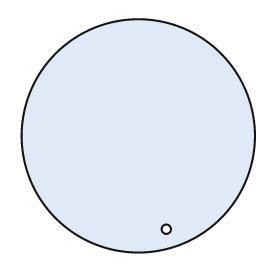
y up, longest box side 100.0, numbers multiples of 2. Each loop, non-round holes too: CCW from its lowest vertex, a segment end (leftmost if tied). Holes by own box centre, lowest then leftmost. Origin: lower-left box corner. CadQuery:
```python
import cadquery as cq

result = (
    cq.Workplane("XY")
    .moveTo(50.0, 50.0)
    .circle(50.0)
    .moveTo(62.0, 10.0)
    .circle(2.0)
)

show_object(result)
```